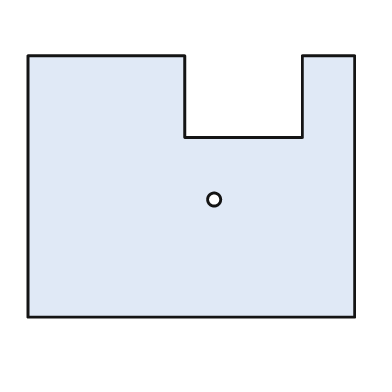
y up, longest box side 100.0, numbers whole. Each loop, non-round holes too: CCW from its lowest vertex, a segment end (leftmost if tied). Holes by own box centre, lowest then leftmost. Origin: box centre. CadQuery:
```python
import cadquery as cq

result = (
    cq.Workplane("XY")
    .moveTo(-50.0, -40.0)
    .lineTo(50.0, -40.0)
    .lineTo(50.0, 40.0)
    .lineTo(34.0, 40.0)
    .lineTo(34.0, 15.0)
    .lineTo(-2.0, 15.0)
    .lineTo(-2.0, 40.0)
    .lineTo(-50.0, 40.0)
    .close()
    .moveTo(7.0, -4.0)
    .circle(2.0)
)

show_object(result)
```